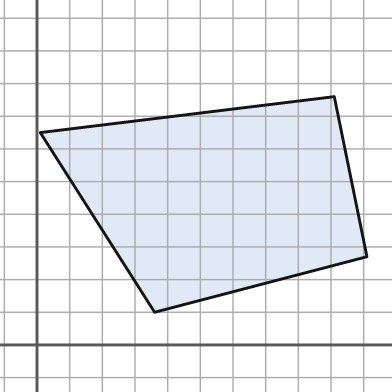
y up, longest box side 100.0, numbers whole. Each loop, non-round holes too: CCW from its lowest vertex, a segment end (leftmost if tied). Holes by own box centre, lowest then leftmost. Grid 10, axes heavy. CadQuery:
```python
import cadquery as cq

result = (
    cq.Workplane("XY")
    .moveTo(36.0, 10.0)
    .lineTo(101.0, 27.0)
    .lineTo(91.0, 76.0)
    .lineTo(1.0, 65.0)
    .close()
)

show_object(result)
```